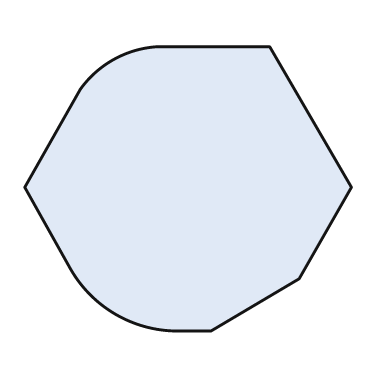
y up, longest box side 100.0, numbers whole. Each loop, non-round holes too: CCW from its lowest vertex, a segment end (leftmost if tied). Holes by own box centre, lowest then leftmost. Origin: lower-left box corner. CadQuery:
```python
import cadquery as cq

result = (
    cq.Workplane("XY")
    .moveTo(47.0, 0.0)
    .lineTo(57.0, 0.0)
    .lineTo(84.0, 16.0)
    .lineTo(100.0, 44.0)
    .lineTo(75.0, 87.0)
    .lineTo(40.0, 87.0)
    .threePointArc((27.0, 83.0), (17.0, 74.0))
    .lineTo(0.0, 44.0)
    .lineTo(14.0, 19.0)
    .threePointArc((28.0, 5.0), (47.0, 0.0))
    .close()
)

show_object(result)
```